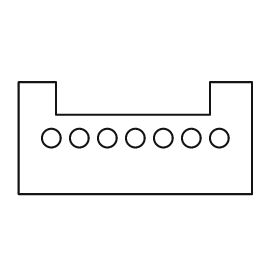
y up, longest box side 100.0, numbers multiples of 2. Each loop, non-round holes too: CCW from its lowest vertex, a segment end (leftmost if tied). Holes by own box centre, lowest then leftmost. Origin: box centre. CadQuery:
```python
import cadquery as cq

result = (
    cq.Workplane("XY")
    .moveTo(-50.0, -24.0)
    .lineTo(50.0, -24.0)
    .lineTo(50.0, 24.0)
    .lineTo(32.0, 24.0)
    .lineTo(32.0, 10.0)
    .lineTo(-34.0, 10.0)
    .lineTo(-34.0, 24.0)
    .lineTo(-50.0, 24.0)
    .close()
    .moveTo(-36.0, 0.0)
    .circle(4.0)
    .moveTo(-24.0, 0.0)
    .circle(4.0)
    .moveTo(-12.0, 0.0)
    .circle(4.0)
    .moveTo(0.0, 0.0)
    .circle(4.0)
    .moveTo(12.0, 0.0)
    .circle(4.0)
    .moveTo(24.0, 0.0)
    .circle(4.0)
    .moveTo(36.0, 0.0)
    .circle(4.0)
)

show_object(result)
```